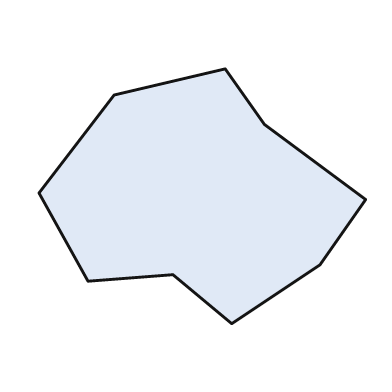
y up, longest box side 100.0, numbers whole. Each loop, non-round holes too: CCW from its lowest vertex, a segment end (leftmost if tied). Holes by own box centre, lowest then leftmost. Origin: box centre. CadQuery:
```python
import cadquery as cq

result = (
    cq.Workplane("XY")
    .moveTo(9.0, -39.0)
    .lineTo(36.0, -21.0)
    .lineTo(50.0, -1.0)
    .lineTo(19.0, 22.0)
    .lineTo(7.0, 39.0)
    .lineTo(-27.0, 31.0)
    .lineTo(-50.0, 1.0)
    .lineTo(-35.0, -26.0)
    .lineTo(-9.0, -24.0)
    .close()
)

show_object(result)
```